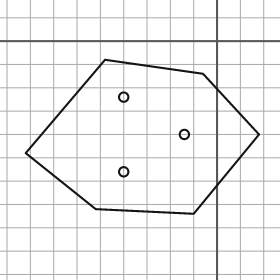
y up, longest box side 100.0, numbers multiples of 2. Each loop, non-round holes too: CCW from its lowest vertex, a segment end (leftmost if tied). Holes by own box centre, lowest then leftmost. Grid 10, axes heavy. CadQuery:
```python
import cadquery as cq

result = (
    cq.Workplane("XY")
    .moveTo(-10.0, -74.0)
    .lineTo(18.0, -40.0)
    .lineTo(-6.0, -14.0)
    .lineTo(-48.0, -8.0)
    .lineTo(-82.0, -48.0)
    .lineTo(-52.0, -72.0)
    .close()
    .moveTo(-40.0, -56.0)
    .circle(2.0)
    .moveTo(-14.0, -40.0)
    .circle(2.0)
    .moveTo(-40.0, -24.0)
    .circle(2.0)
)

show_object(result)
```